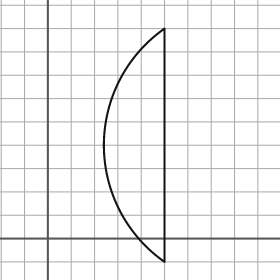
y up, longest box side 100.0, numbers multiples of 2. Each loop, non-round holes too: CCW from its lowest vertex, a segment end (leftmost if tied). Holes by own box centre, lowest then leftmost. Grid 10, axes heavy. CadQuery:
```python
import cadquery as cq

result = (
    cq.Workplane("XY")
    .moveTo(50.0, -10.0)
    .lineTo(50.0, 90.0)
    .threePointArc((24.0, 40.0), (50.0, -10.0))
    .close()
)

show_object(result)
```